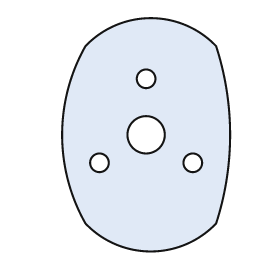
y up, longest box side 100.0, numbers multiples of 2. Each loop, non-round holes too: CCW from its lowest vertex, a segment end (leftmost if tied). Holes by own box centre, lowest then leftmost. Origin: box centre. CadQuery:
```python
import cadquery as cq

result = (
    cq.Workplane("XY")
    .moveTo(-26.0, -38.0)
    .threePointArc((2.0, -50.0), (30.0, -38.0))
    .threePointArc((36.0, 0.0), (30.0, 38.0))
    .threePointArc((2.0, 50.0), (-26.0, 38.0))
    .threePointArc((-36.0, 0.0), (-26.0, -38.0))
    .close()
    .moveTo(-20.0, -12.0)
    .circle(4.0)
    .moveTo(20.0, -12.0)
    .circle(4.0)
    .moveTo(0.0, 0.0)
    .circle(8.0)
    .moveTo(0.0, 24.0)
    .circle(4.0)
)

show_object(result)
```